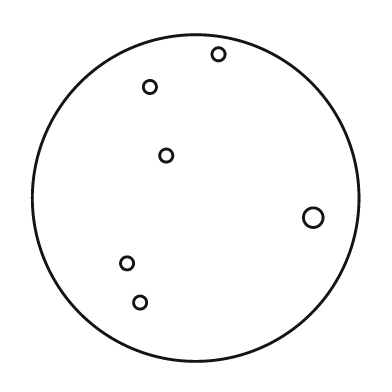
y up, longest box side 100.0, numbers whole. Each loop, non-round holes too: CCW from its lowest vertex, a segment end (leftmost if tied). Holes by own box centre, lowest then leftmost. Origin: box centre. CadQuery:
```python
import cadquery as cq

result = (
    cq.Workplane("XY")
    .moveTo(0.0, 0.0)
    .circle(50.0)
    .moveTo(-17.0, -32.0)
    .circle(2.0)
    .moveTo(-21.0, -20.0)
    .circle(2.0)
    .moveTo(36.0, -6.0)
    .circle(3.0)
    .moveTo(-9.0, 13.0)
    .circle(2.0)
    .moveTo(-14.0, 34.0)
    .circle(2.0)
    .moveTo(7.0, 44.0)
    .circle(2.0)
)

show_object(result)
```